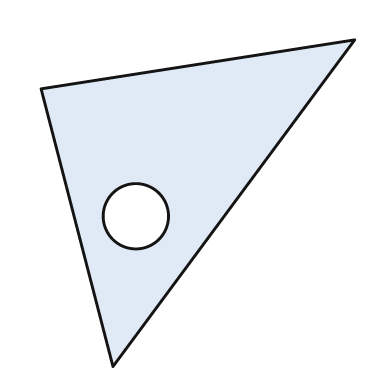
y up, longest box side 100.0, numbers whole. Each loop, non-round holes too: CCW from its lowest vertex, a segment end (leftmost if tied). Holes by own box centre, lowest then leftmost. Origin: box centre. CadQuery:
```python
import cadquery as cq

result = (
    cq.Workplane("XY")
    .moveTo(-26.0, -50.0)
    .lineTo(48.0, 50.0)
    .lineTo(-48.0, 35.0)
    .close()
    .moveTo(-19.0, -4.0)
    .circle(10.0)
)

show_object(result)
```